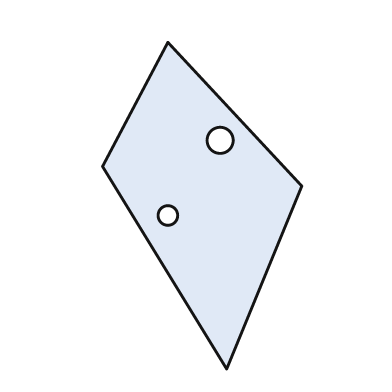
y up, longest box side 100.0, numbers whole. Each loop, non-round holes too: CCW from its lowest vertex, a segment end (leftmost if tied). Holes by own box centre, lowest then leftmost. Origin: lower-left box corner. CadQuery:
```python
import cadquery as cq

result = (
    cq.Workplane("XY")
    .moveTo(38.0, 0.0)
    .lineTo(61.0, 56.0)
    .lineTo(20.0, 100.0)
    .lineTo(0.0, 62.0)
    .close()
    .moveTo(20.0, 47.0)
    .circle(3.0)
    .moveTo(36.0, 70.0)
    .circle(4.0)
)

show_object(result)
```